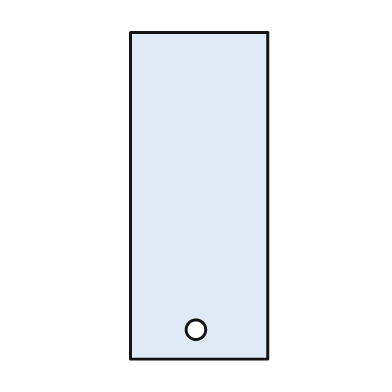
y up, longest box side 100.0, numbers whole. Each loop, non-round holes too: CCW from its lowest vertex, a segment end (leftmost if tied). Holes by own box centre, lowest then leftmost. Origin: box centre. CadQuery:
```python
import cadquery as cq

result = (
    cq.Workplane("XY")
    .moveTo(-21.0, -50.0)
    .lineTo(21.0, -50.0)
    .lineTo(21.0, 50.0)
    .lineTo(-21.0, 50.0)
    .close()
    .moveTo(-1.0, -41.0)
    .circle(3.0)
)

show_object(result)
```